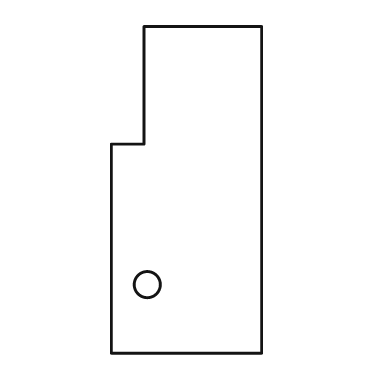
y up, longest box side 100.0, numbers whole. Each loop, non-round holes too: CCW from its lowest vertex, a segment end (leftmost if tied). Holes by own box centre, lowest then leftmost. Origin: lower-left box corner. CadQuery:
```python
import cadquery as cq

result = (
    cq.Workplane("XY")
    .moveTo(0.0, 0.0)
    .lineTo(46.0, 0.0)
    .lineTo(46.0, 100.0)
    .lineTo(10.0, 100.0)
    .lineTo(10.0, 64.0)
    .lineTo(0.0, 64.0)
    .close()
    .moveTo(11.0, 21.0)
    .circle(4.0)
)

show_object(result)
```